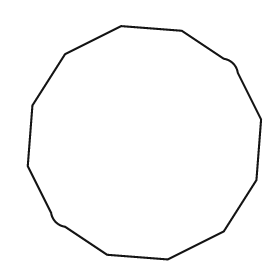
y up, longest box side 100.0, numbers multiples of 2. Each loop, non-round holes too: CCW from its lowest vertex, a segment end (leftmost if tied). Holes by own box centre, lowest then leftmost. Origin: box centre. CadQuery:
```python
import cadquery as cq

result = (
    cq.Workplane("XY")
    .moveTo(10.0, -50.0)
    .lineTo(34.0, -38.0)
    .lineTo(48.0, -16.0)
    .lineTo(50.0, 10.0)
    .lineTo(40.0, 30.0)
    .threePointArc((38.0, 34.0), (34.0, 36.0))
    .lineTo(16.0, 48.0)
    .lineTo(-10.0, 50.0)
    .lineTo(-34.0, 38.0)
    .lineTo(-48.0, 16.0)
    .lineTo(-50.0, -10.0)
    .lineTo(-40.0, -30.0)
    .threePointArc((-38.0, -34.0), (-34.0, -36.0))
    .lineTo(-16.0, -48.0)
    .close()
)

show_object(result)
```